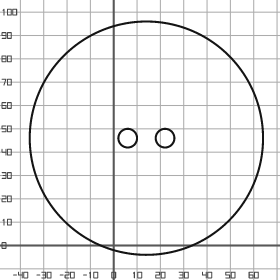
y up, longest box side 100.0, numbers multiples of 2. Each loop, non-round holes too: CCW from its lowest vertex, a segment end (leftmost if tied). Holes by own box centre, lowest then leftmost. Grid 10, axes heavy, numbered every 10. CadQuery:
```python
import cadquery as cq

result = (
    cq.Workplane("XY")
    .moveTo(14.0, 46.0)
    .circle(50.0)
    .moveTo(6.0, 46.0)
    .circle(4.0)
    .moveTo(22.0, 46.0)
    .circle(4.0)
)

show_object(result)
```